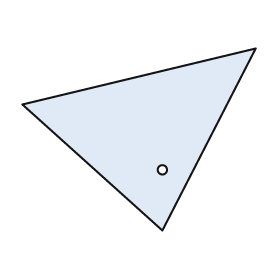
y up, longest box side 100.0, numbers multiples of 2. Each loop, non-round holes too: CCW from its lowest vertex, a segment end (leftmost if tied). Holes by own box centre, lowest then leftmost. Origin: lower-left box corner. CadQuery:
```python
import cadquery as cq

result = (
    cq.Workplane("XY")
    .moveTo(60.0, 0.0)
    .lineTo(100.0, 78.0)
    .lineTo(0.0, 54.0)
    .close()
    .moveTo(60.0, 26.0)
    .circle(2.0)
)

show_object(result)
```